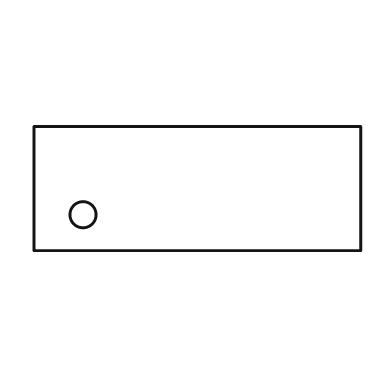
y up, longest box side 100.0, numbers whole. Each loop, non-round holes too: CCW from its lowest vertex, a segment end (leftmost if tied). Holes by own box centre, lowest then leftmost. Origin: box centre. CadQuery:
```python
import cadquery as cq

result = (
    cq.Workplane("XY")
    .moveTo(-50.0, -19.0)
    .lineTo(50.0, -19.0)
    .lineTo(50.0, 19.0)
    .lineTo(-50.0, 19.0)
    .close()
    .moveTo(-35.0, -8.0)
    .circle(4.0)
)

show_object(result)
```